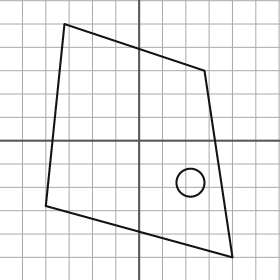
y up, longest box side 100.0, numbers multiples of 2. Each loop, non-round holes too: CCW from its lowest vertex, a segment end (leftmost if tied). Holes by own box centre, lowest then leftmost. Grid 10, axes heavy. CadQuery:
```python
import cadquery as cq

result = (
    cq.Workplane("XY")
    .moveTo(40.0, -50.0)
    .lineTo(28.0, 30.0)
    .lineTo(-32.0, 50.0)
    .lineTo(-40.0, -28.0)
    .close()
    .moveTo(22.0, -18.0)
    .circle(6.0)
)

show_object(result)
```